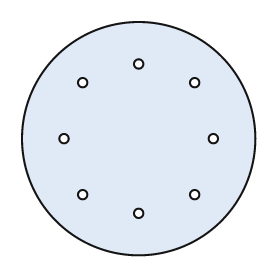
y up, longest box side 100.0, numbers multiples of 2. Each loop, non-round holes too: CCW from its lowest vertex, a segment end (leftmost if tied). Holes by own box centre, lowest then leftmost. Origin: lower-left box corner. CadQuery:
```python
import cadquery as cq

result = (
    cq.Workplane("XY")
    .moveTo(50.0, 50.0)
    .circle(50.0)
    .moveTo(50.0, 18.0)
    .circle(2.0)
    .moveTo(26.0, 26.0)
    .circle(2.0)
    .moveTo(74.0, 26.0)
    .circle(2.0)
    .moveTo(18.0, 50.0)
    .circle(2.0)
    .moveTo(82.0, 50.0)
    .circle(2.0)
    .moveTo(26.0, 74.0)
    .circle(2.0)
    .moveTo(74.0, 74.0)
    .circle(2.0)
    .moveTo(50.0, 82.0)
    .circle(2.0)
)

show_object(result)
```